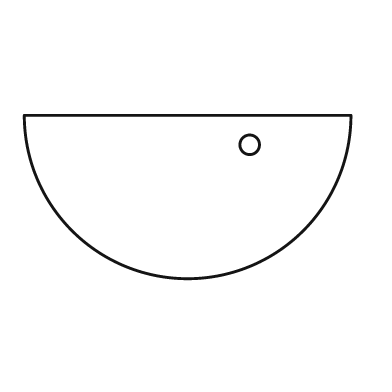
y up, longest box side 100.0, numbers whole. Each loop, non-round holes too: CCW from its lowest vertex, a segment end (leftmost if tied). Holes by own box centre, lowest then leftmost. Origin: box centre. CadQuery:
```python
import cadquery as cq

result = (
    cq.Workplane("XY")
    .moveTo(-50.0, 25.0)
    .threePointArc((0.0, -25.0), (50.0, 25.0))
    .close()
    .moveTo(19.0, 16.0)
    .circle(3.0)
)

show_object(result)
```